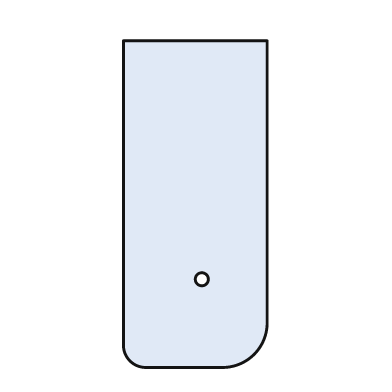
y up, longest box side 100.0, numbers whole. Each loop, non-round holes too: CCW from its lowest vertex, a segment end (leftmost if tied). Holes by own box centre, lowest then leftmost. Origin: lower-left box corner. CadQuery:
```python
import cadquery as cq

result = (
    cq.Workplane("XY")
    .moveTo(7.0, 0.0)
    .lineTo(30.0, 0.0)
    .threePointArc((40.0, 4.0), (44.0, 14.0))
    .lineTo(44.0, 100.0)
    .lineTo(0.0, 100.0)
    .lineTo(0.0, 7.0)
    .threePointArc((2.0, 2.0), (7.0, 0.0))
    .close()
    .moveTo(24.0, 27.0)
    .circle(2.0)
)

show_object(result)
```